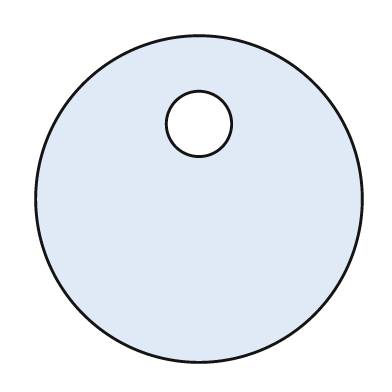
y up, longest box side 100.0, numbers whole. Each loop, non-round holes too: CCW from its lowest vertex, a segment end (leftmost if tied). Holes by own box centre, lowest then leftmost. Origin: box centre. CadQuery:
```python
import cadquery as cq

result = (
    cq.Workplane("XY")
    .moveTo(0.0, 0.0)
    .circle(50.0)
    .moveTo(0.0, 23.0)
    .circle(10.0)
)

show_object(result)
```